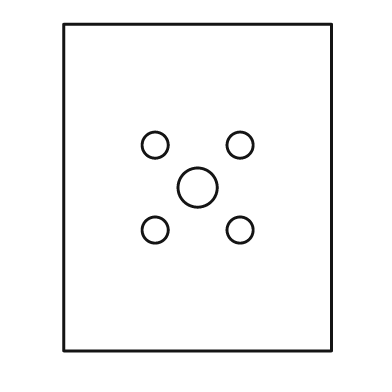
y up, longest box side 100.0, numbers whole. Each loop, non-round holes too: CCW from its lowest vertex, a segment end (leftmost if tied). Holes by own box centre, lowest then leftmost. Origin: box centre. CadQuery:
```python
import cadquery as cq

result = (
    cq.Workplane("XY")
    .moveTo(-41.0, -50.0)
    .lineTo(41.0, -50.0)
    .lineTo(41.0, 50.0)
    .lineTo(-41.0, 50.0)
    .close()
    .moveTo(-13.0, -13.0)
    .circle(4.0)
    .moveTo(13.0, -13.0)
    .circle(4.0)
    .moveTo(0.0, 0.0)
    .circle(6.0)
    .moveTo(-13.0, 13.0)
    .circle(4.0)
    .moveTo(13.0, 13.0)
    .circle(4.0)
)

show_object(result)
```